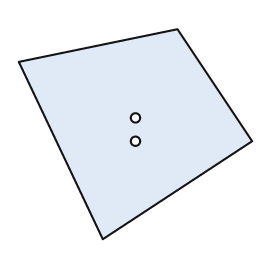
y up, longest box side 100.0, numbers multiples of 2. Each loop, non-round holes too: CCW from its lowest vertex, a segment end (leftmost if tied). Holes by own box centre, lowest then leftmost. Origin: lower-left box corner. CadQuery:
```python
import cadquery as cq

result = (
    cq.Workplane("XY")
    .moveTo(36.0, 0.0)
    .lineTo(100.0, 42.0)
    .lineTo(68.0, 90.0)
    .lineTo(0.0, 76.0)
    .close()
    .moveTo(50.0, 42.0)
    .circle(2.0)
    .moveTo(50.0, 52.0)
    .circle(2.0)
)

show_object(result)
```